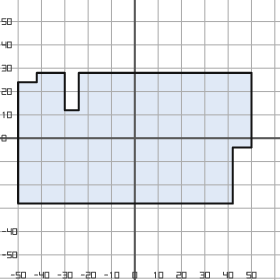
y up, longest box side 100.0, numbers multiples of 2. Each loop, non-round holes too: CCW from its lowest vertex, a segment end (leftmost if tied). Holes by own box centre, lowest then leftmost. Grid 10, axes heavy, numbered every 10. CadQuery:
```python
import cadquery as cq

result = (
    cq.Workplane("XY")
    .moveTo(-50.0, -28.0)
    .lineTo(42.0, -28.0)
    .lineTo(42.0, -4.0)
    .lineTo(50.0, -4.0)
    .lineTo(50.0, 28.0)
    .lineTo(-24.0, 28.0)
    .lineTo(-24.0, 12.0)
    .lineTo(-30.0, 12.0)
    .lineTo(-30.0, 28.0)
    .lineTo(-42.0, 28.0)
    .lineTo(-42.0, 24.0)
    .lineTo(-50.0, 24.0)
    .close()
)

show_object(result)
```